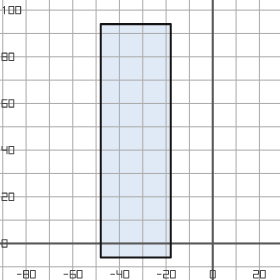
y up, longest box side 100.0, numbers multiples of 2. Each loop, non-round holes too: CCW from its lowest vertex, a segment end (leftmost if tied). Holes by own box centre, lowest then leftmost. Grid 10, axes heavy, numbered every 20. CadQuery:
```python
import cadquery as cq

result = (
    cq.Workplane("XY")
    .moveTo(-48.0, -6.0)
    .lineTo(-18.0, -6.0)
    .lineTo(-18.0, 94.0)
    .lineTo(-48.0, 94.0)
    .close()
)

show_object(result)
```